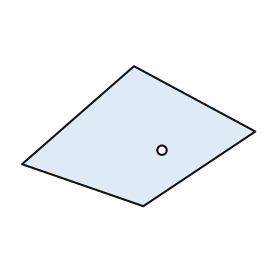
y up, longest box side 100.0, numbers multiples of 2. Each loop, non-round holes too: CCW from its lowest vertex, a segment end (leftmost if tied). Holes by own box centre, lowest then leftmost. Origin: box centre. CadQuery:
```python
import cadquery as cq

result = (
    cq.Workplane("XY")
    .moveTo(2.0, -30.0)
    .lineTo(50.0, 2.0)
    .lineTo(-2.0, 30.0)
    .lineTo(-50.0, -12.0)
    .close()
    .moveTo(10.0, -6.0)
    .circle(2.0)
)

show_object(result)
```